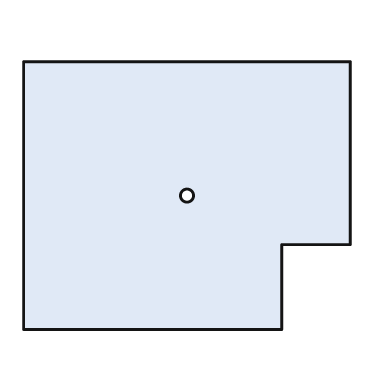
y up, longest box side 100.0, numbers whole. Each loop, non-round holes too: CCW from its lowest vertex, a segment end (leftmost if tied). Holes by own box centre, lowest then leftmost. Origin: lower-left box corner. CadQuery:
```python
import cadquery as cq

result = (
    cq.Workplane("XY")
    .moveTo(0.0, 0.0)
    .lineTo(79.0, 0.0)
    .lineTo(79.0, 26.0)
    .lineTo(100.0, 26.0)
    .lineTo(100.0, 82.0)
    .lineTo(0.0, 82.0)
    .close()
    .moveTo(50.0, 41.0)
    .circle(2.0)
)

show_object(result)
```